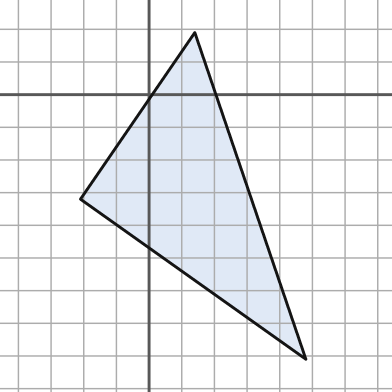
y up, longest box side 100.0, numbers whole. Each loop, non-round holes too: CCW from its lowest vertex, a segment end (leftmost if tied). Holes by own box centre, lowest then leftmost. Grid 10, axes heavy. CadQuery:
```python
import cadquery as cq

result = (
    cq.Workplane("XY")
    .moveTo(48.0, -81.0)
    .lineTo(14.0, 19.0)
    .lineTo(-21.0, -32.0)
    .close()
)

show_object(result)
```